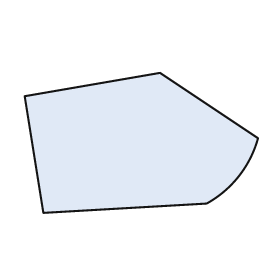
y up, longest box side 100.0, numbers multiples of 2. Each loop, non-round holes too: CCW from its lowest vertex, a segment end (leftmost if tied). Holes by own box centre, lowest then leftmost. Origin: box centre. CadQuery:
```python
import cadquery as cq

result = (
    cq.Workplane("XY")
    .moveTo(-42.0, -30.0)
    .lineTo(28.0, -26.0)
    .threePointArc((42.0, -14.0), (50.0, 2.0))
    .lineTo(8.0, 30.0)
    .lineTo(-50.0, 20.0)
    .close()
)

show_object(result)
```